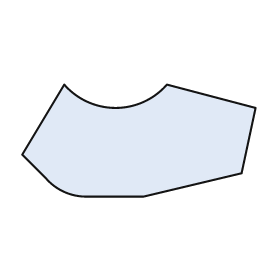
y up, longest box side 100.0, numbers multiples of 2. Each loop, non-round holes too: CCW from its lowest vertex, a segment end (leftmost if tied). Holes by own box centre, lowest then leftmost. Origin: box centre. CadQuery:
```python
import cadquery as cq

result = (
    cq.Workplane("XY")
    .moveTo(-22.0, -24.0)
    .lineTo(2.0, -24.0)
    .lineTo(44.0, -14.0)
    .lineTo(50.0, 14.0)
    .lineTo(12.0, 24.0)
    .threePointArc((-10.0, 14.0), (-32.0, 24.0))
    .lineTo(-50.0, -6.0)
    .lineTo(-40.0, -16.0)
    .threePointArc((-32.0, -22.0), (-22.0, -24.0))
    .close()
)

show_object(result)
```